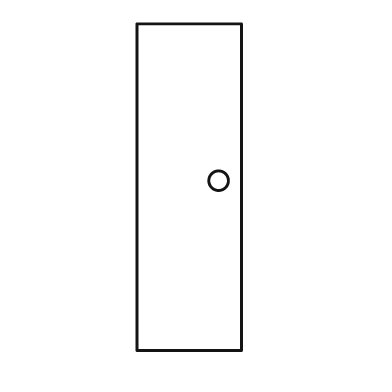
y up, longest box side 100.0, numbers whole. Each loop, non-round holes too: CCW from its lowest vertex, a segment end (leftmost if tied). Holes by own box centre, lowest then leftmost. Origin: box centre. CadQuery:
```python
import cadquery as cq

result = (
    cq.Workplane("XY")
    .moveTo(-16.0, -50.0)
    .lineTo(16.0, -50.0)
    .lineTo(16.0, 50.0)
    .lineTo(-16.0, 50.0)
    .close()
    .moveTo(9.0, 2.0)
    .circle(3.0)
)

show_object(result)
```